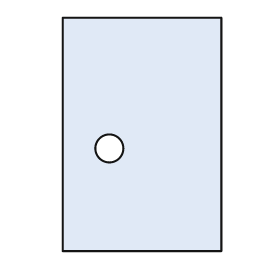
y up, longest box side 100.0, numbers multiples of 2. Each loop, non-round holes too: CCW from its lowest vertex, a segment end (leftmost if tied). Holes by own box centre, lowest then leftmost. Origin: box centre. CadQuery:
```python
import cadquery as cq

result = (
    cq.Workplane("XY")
    .moveTo(-34.0, -50.0)
    .lineTo(34.0, -50.0)
    .lineTo(34.0, 50.0)
    .lineTo(-34.0, 50.0)
    .close()
    .moveTo(-14.0, -6.0)
    .circle(6.0)
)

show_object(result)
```